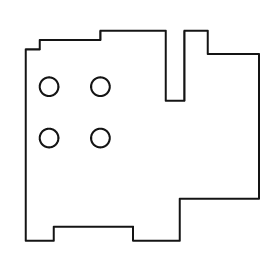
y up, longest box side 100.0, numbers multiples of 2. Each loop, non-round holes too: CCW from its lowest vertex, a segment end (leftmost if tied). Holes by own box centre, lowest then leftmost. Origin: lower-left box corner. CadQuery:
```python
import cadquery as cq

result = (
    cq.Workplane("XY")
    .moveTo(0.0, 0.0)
    .lineTo(12.0, 0.0)
    .lineTo(12.0, 6.0)
    .lineTo(46.0, 6.0)
    .lineTo(46.0, 0.0)
    .lineTo(66.0, 0.0)
    .lineTo(66.0, 18.0)
    .lineTo(100.0, 18.0)
    .lineTo(100.0, 80.0)
    .lineTo(78.0, 80.0)
    .lineTo(78.0, 90.0)
    .lineTo(68.0, 90.0)
    .lineTo(68.0, 60.0)
    .lineTo(60.0, 60.0)
    .lineTo(60.0, 90.0)
    .lineTo(32.0, 90.0)
    .lineTo(32.0, 86.0)
    .lineTo(6.0, 86.0)
    .lineTo(6.0, 82.0)
    .lineTo(0.0, 82.0)
    .close()
    .moveTo(10.0, 44.0)
    .circle(4.0)
    .moveTo(32.0, 44.0)
    .circle(4.0)
    .moveTo(10.0, 66.0)
    .circle(4.0)
    .moveTo(32.0, 66.0)
    .circle(4.0)
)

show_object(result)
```